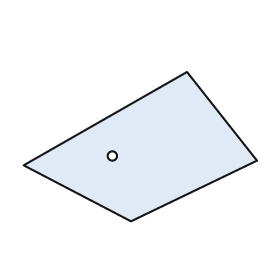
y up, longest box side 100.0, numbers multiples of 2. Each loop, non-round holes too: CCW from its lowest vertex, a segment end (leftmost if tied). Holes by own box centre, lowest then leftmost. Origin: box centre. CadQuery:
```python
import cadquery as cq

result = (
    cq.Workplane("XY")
    .moveTo(-4.0, -32.0)
    .lineTo(50.0, -6.0)
    .lineTo(20.0, 32.0)
    .lineTo(-50.0, -8.0)
    .close()
    .moveTo(-12.0, -4.0)
    .circle(2.0)
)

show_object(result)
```